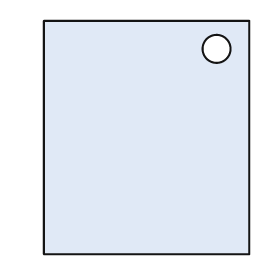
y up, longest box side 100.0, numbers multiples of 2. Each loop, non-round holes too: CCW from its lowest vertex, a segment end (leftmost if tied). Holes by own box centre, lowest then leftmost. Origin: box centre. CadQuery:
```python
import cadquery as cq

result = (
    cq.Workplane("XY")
    .moveTo(-44.0, -50.0)
    .lineTo(44.0, -50.0)
    .lineTo(44.0, 50.0)
    .lineTo(-44.0, 50.0)
    .close()
    .moveTo(30.0, 38.0)
    .circle(6.0)
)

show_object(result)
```